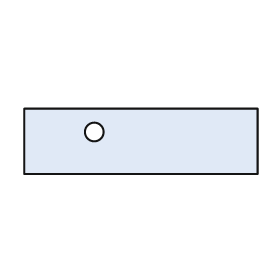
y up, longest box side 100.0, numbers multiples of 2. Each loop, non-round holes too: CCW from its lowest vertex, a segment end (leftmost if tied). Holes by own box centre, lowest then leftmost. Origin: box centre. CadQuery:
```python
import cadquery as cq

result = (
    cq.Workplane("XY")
    .moveTo(-50.0, -14.0)
    .lineTo(50.0, -14.0)
    .lineTo(50.0, 14.0)
    .lineTo(-50.0, 14.0)
    .close()
    .moveTo(-20.0, 4.0)
    .circle(4.0)
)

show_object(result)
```